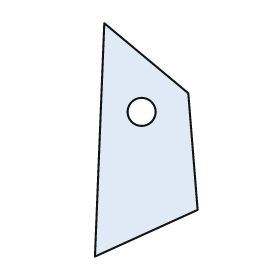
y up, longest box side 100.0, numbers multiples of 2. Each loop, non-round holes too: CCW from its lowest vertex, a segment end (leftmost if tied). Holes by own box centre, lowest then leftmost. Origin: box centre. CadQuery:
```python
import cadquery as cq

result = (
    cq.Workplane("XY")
    .moveTo(-22.0, -50.0)
    .lineTo(22.0, -30.0)
    .lineTo(18.0, 20.0)
    .lineTo(-18.0, 50.0)
    .close()
    .moveTo(-2.0, 12.0)
    .circle(6.0)
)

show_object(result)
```